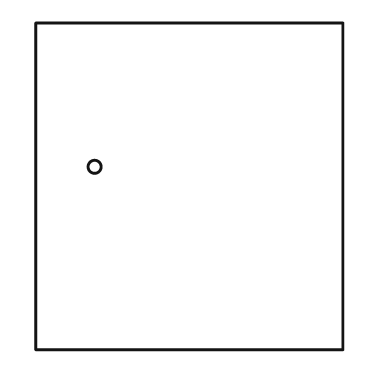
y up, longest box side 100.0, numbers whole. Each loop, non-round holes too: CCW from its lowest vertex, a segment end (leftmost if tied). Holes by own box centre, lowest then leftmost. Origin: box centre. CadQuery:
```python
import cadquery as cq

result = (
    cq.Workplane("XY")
    .moveTo(-47.0, -50.0)
    .lineTo(47.0, -50.0)
    .lineTo(47.0, 50.0)
    .lineTo(-47.0, 50.0)
    .close()
    .moveTo(-29.0, 6.0)
    .circle(2.0)
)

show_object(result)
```